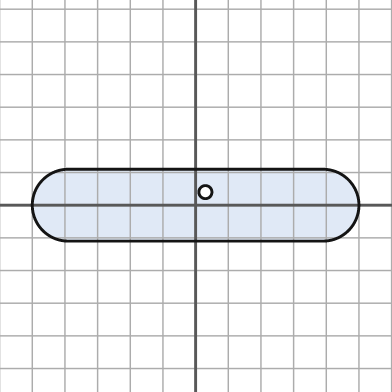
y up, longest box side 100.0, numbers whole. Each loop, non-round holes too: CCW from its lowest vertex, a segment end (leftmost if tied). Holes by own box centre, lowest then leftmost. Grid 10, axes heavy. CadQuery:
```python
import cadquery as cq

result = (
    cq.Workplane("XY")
    .moveTo(-39.0, -11.0)
    .lineTo(39.0, -11.0)
    .threePointArc((50.0, 0.0), (39.0, 11.0))
    .lineTo(-39.0, 11.0)
    .threePointArc((-50.0, 0.0), (-39.0, -11.0))
    .close()
    .moveTo(3.0, 4.0)
    .circle(2.0)
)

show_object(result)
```